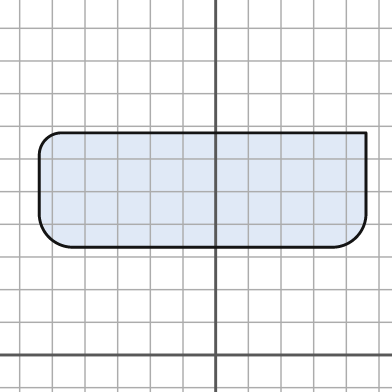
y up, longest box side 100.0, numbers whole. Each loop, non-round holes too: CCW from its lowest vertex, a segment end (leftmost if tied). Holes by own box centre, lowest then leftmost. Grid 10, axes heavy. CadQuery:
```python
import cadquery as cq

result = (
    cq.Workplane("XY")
    .moveTo(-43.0, 33.0)
    .lineTo(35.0, 33.0)
    .threePointArc((43.0, 36.0), (46.0, 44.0))
    .lineTo(46.0, 68.0)
    .lineTo(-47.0, 68.0)
    .threePointArc((-52.0, 66.0), (-54.0, 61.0))
    .lineTo(-54.0, 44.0)
    .threePointArc((-51.0, 36.0), (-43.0, 33.0))
    .close()
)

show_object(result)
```